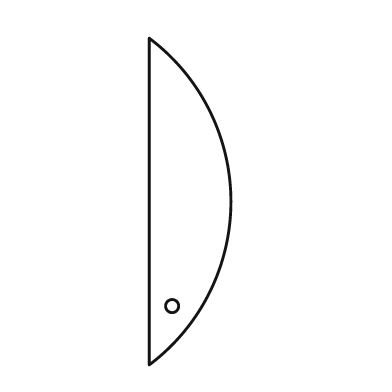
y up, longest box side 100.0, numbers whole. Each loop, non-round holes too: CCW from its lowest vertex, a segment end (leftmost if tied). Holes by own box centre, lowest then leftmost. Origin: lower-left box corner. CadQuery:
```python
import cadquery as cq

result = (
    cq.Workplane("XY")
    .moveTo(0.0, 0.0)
    .threePointArc((25.0, 50.0), (0.0, 100.0))
    .close()
    .moveTo(7.0, 18.0)
    .circle(2.0)
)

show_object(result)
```